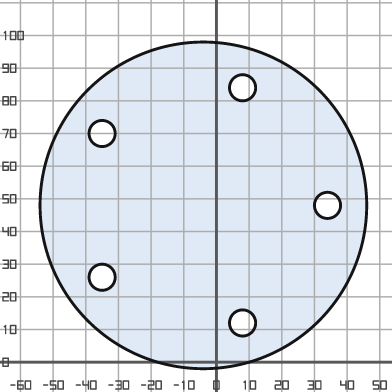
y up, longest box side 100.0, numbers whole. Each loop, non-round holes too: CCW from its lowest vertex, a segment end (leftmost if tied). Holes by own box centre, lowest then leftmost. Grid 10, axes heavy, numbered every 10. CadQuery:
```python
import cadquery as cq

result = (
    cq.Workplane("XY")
    .moveTo(-4.0, 48.0)
    .circle(50.0)
    .moveTo(8.0, 12.0)
    .circle(4.0)
    .moveTo(-35.0, 26.0)
    .circle(4.0)
    .moveTo(34.0, 48.0)
    .circle(4.0)
    .moveTo(-35.0, 70.0)
    .circle(4.0)
    .moveTo(8.0, 84.0)
    .circle(4.0)
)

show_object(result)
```